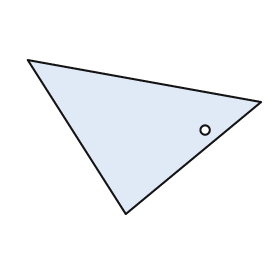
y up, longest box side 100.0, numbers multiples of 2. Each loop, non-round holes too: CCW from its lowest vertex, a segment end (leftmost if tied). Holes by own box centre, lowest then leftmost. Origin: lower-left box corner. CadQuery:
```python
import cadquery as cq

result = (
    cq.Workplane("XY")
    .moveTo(42.0, 0.0)
    .lineTo(100.0, 48.0)
    .lineTo(0.0, 66.0)
    .close()
    .moveTo(76.0, 36.0)
    .circle(2.0)
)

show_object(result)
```